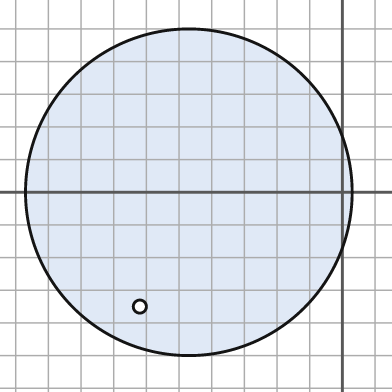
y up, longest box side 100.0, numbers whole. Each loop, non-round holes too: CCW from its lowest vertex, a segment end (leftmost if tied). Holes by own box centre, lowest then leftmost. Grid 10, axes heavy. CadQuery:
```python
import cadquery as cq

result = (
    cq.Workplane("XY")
    .moveTo(-47.0, 0.0)
    .circle(50.0)
    .moveTo(-62.0, -35.0)
    .circle(2.0)
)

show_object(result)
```